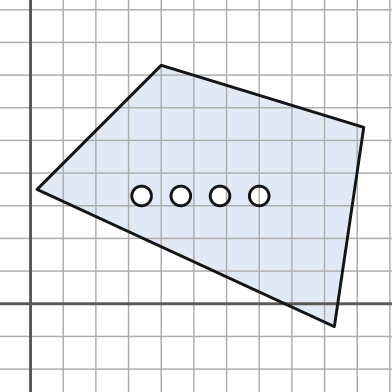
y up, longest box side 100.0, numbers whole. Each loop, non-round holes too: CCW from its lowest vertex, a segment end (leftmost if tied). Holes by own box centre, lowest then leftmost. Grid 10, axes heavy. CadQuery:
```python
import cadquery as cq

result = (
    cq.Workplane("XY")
    .moveTo(93.0, -7.0)
    .lineTo(102.0, 54.0)
    .lineTo(40.0, 73.0)
    .lineTo(2.0, 35.0)
    .close()
    .moveTo(34.0, 33.0)
    .circle(3.0)
    .moveTo(46.0, 33.0)
    .circle(3.0)
    .moveTo(58.0, 33.0)
    .circle(3.0)
    .moveTo(70.0, 33.0)
    .circle(3.0)
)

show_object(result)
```